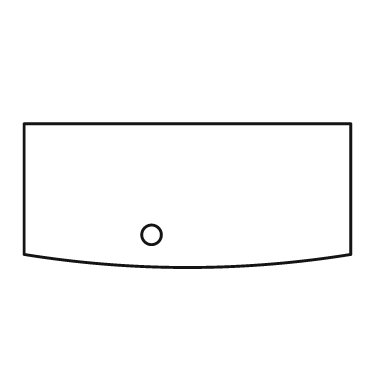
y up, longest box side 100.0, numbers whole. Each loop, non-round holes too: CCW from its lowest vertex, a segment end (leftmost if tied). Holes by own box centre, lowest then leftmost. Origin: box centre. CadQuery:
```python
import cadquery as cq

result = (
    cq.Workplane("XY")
    .moveTo(-50.0, -18.0)
    .threePointArc((0.0, -22.0), (50.0, -18.0))
    .lineTo(50.0, 22.0)
    .lineTo(-50.0, 22.0)
    .close()
    .moveTo(-11.0, -12.0)
    .circle(3.0)
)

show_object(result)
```